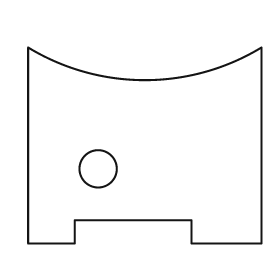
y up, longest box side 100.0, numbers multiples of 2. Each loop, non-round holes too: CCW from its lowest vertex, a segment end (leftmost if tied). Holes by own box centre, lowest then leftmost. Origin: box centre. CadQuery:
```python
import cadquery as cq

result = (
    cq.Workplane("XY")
    .moveTo(-50.0, -42.0)
    .lineTo(-30.0, -42.0)
    .lineTo(-30.0, -32.0)
    .lineTo(20.0, -32.0)
    .lineTo(20.0, -42.0)
    .lineTo(50.0, -42.0)
    .lineTo(50.0, 42.0)
    .threePointArc((0.0, 28.0), (-50.0, 42.0))
    .close()
    .moveTo(-20.0, -10.0)
    .circle(8.0)
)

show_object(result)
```